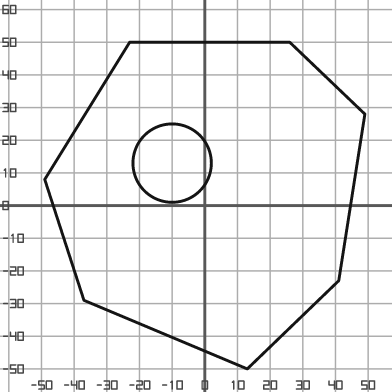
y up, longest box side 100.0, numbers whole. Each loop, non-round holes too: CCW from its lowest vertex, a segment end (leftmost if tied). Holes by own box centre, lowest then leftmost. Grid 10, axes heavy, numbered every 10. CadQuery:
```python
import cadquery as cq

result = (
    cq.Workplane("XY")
    .moveTo(13.0, -50.0)
    .lineTo(41.0, -23.0)
    .lineTo(49.0, 28.0)
    .lineTo(26.0, 50.0)
    .lineTo(-23.0, 50.0)
    .lineTo(-49.0, 8.0)
    .lineTo(-37.0, -29.0)
    .close()
    .moveTo(-10.0, 13.0)
    .circle(12.0)
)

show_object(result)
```